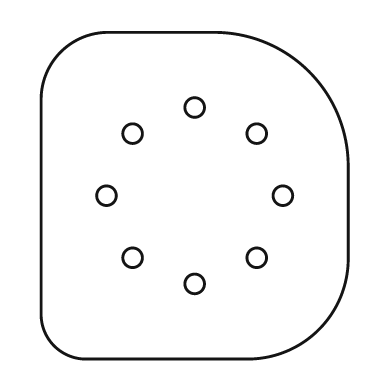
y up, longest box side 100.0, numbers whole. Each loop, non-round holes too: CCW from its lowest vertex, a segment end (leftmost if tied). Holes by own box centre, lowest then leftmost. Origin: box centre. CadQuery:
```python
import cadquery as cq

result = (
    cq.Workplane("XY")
    .moveTo(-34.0, -50.0)
    .lineTo(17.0, -50.0)
    .threePointArc((38.0, -41.0), (47.0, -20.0))
    .lineTo(47.0, 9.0)
    .threePointArc((35.0, 38.0), (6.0, 50.0))
    .lineTo(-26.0, 50.0)
    .threePointArc((-41.0, 44.0), (-47.0, 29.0))
    .lineTo(-47.0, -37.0)
    .threePointArc((-43.0, -46.0), (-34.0, -50.0))
    .close()
    .moveTo(0.0, -27.0)
    .circle(3.0)
    .moveTo(-19.0, -19.0)
    .circle(3.0)
    .moveTo(19.0, -19.0)
    .circle(3.0)
    .moveTo(-27.0, 0.0)
    .circle(3.0)
    .moveTo(27.0, 0.0)
    .circle(3.0)
    .moveTo(-19.0, 19.0)
    .circle(3.0)
    .moveTo(19.0, 19.0)
    .circle(3.0)
    .moveTo(0.0, 27.0)
    .circle(3.0)
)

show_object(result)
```